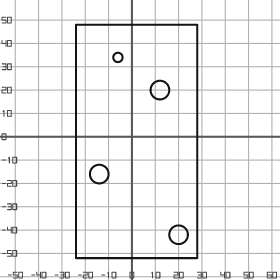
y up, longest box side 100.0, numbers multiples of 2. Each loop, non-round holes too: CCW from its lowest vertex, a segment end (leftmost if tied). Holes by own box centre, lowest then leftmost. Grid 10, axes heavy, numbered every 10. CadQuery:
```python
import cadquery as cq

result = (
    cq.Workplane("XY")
    .moveTo(-24.0, -52.0)
    .lineTo(28.0, -52.0)
    .lineTo(28.0, 48.0)
    .lineTo(-24.0, 48.0)
    .close()
    .moveTo(20.0, -42.0)
    .circle(4.0)
    .moveTo(-14.0, -16.0)
    .circle(4.0)
    .moveTo(12.0, 20.0)
    .circle(4.0)
    .moveTo(-6.0, 34.0)
    .circle(2.0)
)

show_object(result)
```